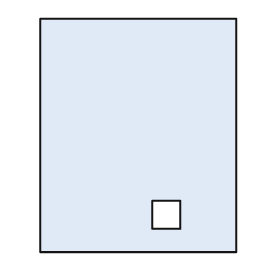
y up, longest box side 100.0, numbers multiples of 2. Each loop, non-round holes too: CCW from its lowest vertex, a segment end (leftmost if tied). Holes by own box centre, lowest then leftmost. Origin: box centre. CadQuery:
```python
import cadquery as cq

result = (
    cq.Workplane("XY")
    .moveTo(-42.0, -50.0)
    .lineTo(42.0, -50.0)
    .lineTo(42.0, 50.0)
    .lineTo(-42.0, 50.0)
    .close()
    .moveTo(6.0, -40.0)
    .lineTo(18.0, -40.0)
    .lineTo(18.0, -28.0)
    .lineTo(6.0, -28.0)
    .close()
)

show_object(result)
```